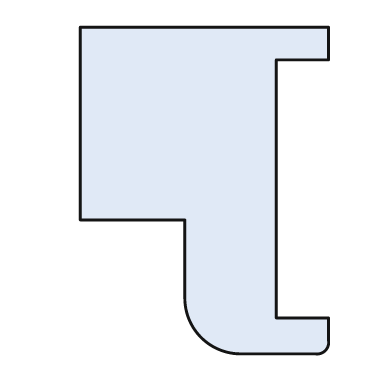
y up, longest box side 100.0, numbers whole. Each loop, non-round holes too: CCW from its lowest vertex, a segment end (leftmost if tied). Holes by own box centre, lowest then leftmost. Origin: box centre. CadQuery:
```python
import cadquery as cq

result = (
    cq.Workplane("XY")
    .moveTo(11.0, -50.0)
    .lineTo(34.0, -50.0)
    .threePointArc((37.0, -49.0), (38.0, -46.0))
    .lineTo(38.0, -39.0)
    .lineTo(22.0, -39.0)
    .lineTo(22.0, 40.0)
    .lineTo(38.0, 40.0)
    .lineTo(38.0, 50.0)
    .lineTo(-38.0, 50.0)
    .lineTo(-38.0, -9.0)
    .lineTo(-6.0, -9.0)
    .lineTo(-6.0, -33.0)
    .threePointArc((-1.0, -45.0), (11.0, -50.0))
    .close()
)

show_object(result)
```